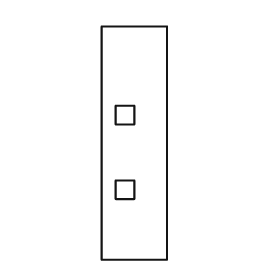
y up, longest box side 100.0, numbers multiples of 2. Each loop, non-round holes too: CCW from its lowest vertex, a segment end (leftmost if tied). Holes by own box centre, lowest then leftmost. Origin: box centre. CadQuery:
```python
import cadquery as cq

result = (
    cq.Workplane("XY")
    .moveTo(-14.0, -50.0)
    .lineTo(14.0, -50.0)
    .lineTo(14.0, 50.0)
    .lineTo(-14.0, 50.0)
    .close()
    .moveTo(-8.0, -24.0)
    .lineTo(0.0, -24.0)
    .lineTo(0.0, -16.0)
    .lineTo(-8.0, -16.0)
    .close()
    .moveTo(-8.0, 8.0)
    .lineTo(0.0, 8.0)
    .lineTo(0.0, 16.0)
    .lineTo(-8.0, 16.0)
    .close()
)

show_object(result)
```